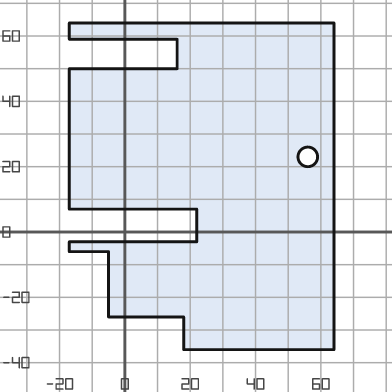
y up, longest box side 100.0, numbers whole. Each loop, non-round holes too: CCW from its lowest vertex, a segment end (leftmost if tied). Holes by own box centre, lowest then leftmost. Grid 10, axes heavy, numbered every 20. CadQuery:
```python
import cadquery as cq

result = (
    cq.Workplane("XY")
    .moveTo(18.0, -36.0)
    .lineTo(64.0, -36.0)
    .lineTo(64.0, 64.0)
    .lineTo(-17.0, 64.0)
    .lineTo(-17.0, 59.0)
    .lineTo(16.0, 59.0)
    .lineTo(16.0, 50.0)
    .lineTo(-17.0, 50.0)
    .lineTo(-17.0, 7.0)
    .lineTo(22.0, 7.0)
    .lineTo(22.0, -3.0)
    .lineTo(-17.0, -3.0)
    .lineTo(-17.0, -6.0)
    .lineTo(-5.0, -6.0)
    .lineTo(-5.0, -26.0)
    .lineTo(18.0, -26.0)
    .close()
    .moveTo(56.0, 23.0)
    .circle(3.0)
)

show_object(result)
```